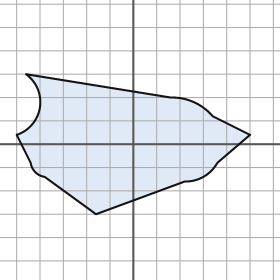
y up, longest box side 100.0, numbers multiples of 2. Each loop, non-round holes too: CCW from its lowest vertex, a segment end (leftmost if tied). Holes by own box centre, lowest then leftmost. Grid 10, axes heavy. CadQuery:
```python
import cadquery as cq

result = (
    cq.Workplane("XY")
    .moveTo(-16.0, -30.0)
    .lineTo(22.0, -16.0)
    .threePointArc((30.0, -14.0), (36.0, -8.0))
    .lineTo(50.0, 4.0)
    .lineTo(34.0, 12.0)
    .threePointArc((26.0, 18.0), (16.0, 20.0))
    .lineTo(-46.0, 30.0)
    .threePointArc((-40.0, 16.0), (-50.0, 4.0))
    .lineTo(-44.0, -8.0)
    .threePointArc((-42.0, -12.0), (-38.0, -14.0))
    .close()
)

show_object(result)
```